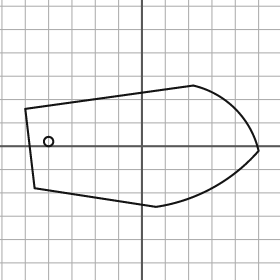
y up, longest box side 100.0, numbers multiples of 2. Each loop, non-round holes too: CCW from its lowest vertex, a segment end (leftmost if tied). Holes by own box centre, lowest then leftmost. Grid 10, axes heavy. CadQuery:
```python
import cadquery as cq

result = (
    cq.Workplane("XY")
    .moveTo(6.0, -26.0)
    .threePointArc((30.0, -18.0), (50.0, -2.0))
    .threePointArc((40.0, 16.0), (22.0, 26.0))
    .lineTo(-50.0, 16.0)
    .lineTo(-46.0, -18.0)
    .close()
    .moveTo(-40.0, 2.0)
    .circle(2.0)
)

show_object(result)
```